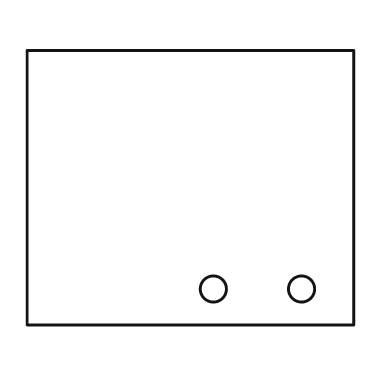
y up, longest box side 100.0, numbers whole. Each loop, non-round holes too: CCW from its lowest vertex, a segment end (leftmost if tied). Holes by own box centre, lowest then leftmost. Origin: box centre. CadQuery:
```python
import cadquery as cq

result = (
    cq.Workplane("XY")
    .moveTo(-50.0, -42.0)
    .lineTo(50.0, -42.0)
    .lineTo(50.0, 42.0)
    .lineTo(-50.0, 42.0)
    .close()
    .moveTo(7.0, -31.0)
    .circle(4.0)
    .moveTo(34.0, -31.0)
    .circle(4.0)
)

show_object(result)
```